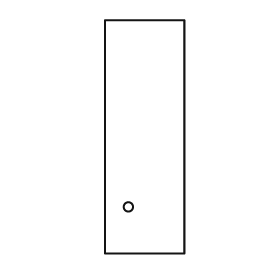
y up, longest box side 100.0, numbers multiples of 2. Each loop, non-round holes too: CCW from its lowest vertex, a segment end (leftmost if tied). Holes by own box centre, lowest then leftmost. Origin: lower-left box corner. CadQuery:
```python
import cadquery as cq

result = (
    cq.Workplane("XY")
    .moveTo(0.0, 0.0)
    .lineTo(34.0, 0.0)
    .lineTo(34.0, 100.0)
    .lineTo(0.0, 100.0)
    .close()
    .moveTo(10.0, 20.0)
    .circle(2.0)
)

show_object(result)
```